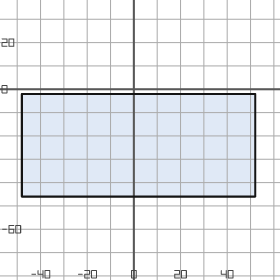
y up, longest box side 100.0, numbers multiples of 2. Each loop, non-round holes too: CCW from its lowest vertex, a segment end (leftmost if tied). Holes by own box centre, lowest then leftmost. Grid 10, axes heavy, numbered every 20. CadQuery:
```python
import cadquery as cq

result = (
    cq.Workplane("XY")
    .moveTo(-48.0, -46.0)
    .lineTo(52.0, -46.0)
    .lineTo(52.0, -2.0)
    .lineTo(-48.0, -2.0)
    .close()
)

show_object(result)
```